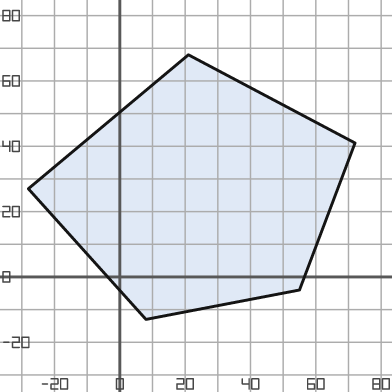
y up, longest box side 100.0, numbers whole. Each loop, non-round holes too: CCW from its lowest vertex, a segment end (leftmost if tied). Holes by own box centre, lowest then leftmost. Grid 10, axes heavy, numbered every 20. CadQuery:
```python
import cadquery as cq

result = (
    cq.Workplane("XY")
    .moveTo(8.0, -13.0)
    .lineTo(55.0, -4.0)
    .lineTo(72.0, 41.0)
    .lineTo(21.0, 68.0)
    .lineTo(-28.0, 27.0)
    .close()
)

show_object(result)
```